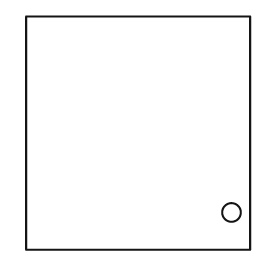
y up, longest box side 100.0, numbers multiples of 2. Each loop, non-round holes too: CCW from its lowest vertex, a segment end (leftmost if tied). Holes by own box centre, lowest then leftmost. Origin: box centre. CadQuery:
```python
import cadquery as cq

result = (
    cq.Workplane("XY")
    .moveTo(-48.0, -50.0)
    .lineTo(48.0, -50.0)
    .lineTo(48.0, 50.0)
    .lineTo(-48.0, 50.0)
    .close()
    .moveTo(40.0, -34.0)
    .circle(4.0)
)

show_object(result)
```